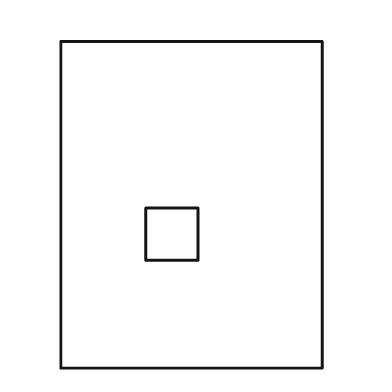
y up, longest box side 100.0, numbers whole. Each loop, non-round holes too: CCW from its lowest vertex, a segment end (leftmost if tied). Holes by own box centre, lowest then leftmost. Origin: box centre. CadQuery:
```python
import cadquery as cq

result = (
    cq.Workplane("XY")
    .moveTo(-40.0, -50.0)
    .lineTo(40.0, -50.0)
    .lineTo(40.0, 50.0)
    .lineTo(-40.0, 50.0)
    .close()
    .moveTo(-14.0, -17.0)
    .lineTo(2.0, -17.0)
    .lineTo(2.0, -1.0)
    .lineTo(-14.0, -1.0)
    .close()
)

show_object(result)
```